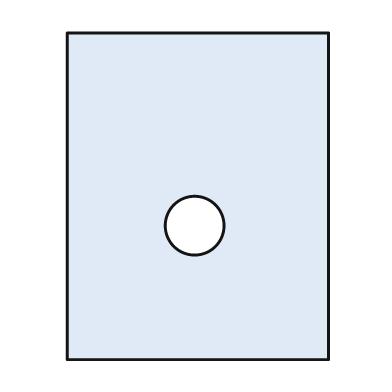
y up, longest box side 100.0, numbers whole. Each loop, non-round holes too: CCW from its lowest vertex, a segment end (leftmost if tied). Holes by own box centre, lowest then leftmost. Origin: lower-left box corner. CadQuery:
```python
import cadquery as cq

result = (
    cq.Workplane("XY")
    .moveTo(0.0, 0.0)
    .lineTo(80.0, 0.0)
    .lineTo(80.0, 100.0)
    .lineTo(0.0, 100.0)
    .close()
    .moveTo(39.0, 41.0)
    .circle(9.0)
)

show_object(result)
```